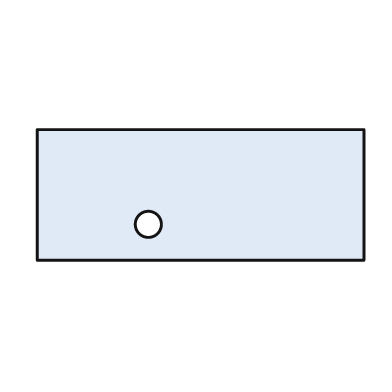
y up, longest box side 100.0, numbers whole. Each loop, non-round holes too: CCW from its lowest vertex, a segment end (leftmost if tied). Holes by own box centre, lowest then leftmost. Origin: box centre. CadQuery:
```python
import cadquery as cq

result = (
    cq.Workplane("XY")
    .moveTo(-50.0, -20.0)
    .lineTo(50.0, -20.0)
    .lineTo(50.0, 20.0)
    .lineTo(-50.0, 20.0)
    .close()
    .moveTo(-16.0, -9.0)
    .circle(4.0)
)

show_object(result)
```